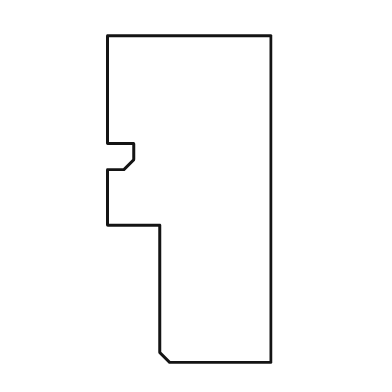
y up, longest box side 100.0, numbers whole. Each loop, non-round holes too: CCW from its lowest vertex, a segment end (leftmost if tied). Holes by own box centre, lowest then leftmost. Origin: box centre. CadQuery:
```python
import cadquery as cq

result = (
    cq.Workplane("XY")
    .moveTo(-6.0, -50.0)
    .lineTo(25.0, -50.0)
    .lineTo(25.0, 50.0)
    .lineTo(-25.0, 50.0)
    .lineTo(-25.0, 17.0)
    .lineTo(-17.0, 17.0)
    .lineTo(-17.0, 12.0)
    .lineTo(-20.0, 9.0)
    .lineTo(-25.0, 9.0)
    .lineTo(-25.0, -8.0)
    .lineTo(-9.0, -8.0)
    .lineTo(-9.0, -47.0)
    .close()
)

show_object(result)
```